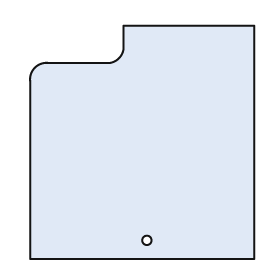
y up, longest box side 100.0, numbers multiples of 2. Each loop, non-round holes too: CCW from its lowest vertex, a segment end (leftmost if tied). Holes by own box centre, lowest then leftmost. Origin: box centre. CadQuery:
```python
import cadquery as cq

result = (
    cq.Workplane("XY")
    .moveTo(-48.0, -50.0)
    .lineTo(48.0, -50.0)
    .lineTo(48.0, 50.0)
    .lineTo(-8.0, 50.0)
    .lineTo(-8.0, 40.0)
    .threePointArc((-10.0, 36.0), (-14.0, 34.0))
    .lineTo(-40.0, 34.0)
    .threePointArc((-46.0, 32.0), (-48.0, 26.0))
    .close()
    .moveTo(2.0, -42.0)
    .circle(2.0)
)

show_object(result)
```